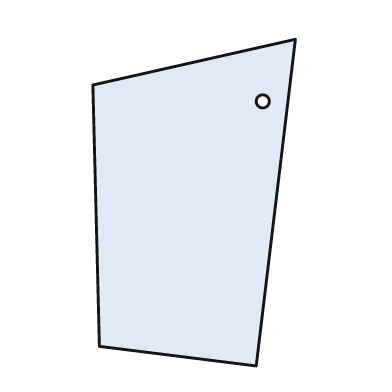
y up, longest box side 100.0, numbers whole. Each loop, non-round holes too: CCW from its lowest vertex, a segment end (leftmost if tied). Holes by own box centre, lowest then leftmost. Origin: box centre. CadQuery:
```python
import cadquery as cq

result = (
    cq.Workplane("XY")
    .moveTo(19.0, -50.0)
    .lineTo(31.0, 50.0)
    .lineTo(-31.0, 36.0)
    .lineTo(-29.0, -44.0)
    .close()
    .moveTo(21.0, 31.0)
    .circle(2.0)
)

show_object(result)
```